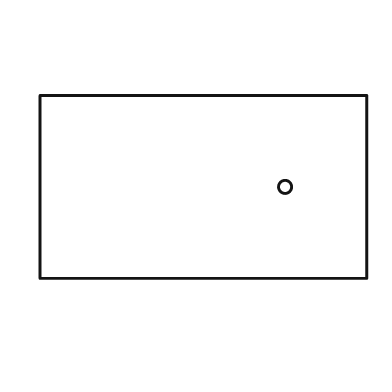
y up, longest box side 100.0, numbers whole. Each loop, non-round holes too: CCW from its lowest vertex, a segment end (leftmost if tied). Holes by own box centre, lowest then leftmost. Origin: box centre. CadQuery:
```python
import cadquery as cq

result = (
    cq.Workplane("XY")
    .moveTo(-50.0, -28.0)
    .lineTo(50.0, -28.0)
    .lineTo(50.0, 28.0)
    .lineTo(-50.0, 28.0)
    .close()
    .moveTo(25.0, 0.0)
    .circle(2.0)
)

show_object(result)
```